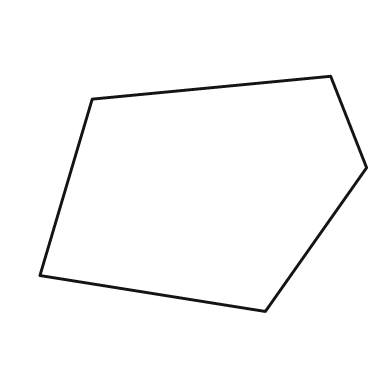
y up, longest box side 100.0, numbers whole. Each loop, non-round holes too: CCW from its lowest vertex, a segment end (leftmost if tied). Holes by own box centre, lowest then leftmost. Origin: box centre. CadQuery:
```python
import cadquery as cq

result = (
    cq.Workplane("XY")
    .moveTo(19.0, -36.0)
    .lineTo(50.0, 8.0)
    .lineTo(39.0, 36.0)
    .lineTo(-34.0, 29.0)
    .lineTo(-50.0, -25.0)
    .close()
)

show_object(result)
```